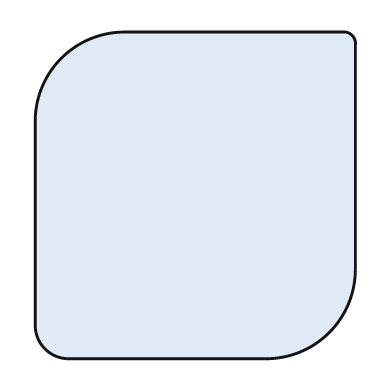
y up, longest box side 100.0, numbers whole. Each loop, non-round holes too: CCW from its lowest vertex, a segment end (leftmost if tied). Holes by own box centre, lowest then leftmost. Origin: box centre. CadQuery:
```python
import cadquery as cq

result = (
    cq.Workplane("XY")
    .moveTo(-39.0, -50.0)
    .lineTo(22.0, -50.0)
    .threePointArc((41.0, -42.0), (49.0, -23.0))
    .lineTo(49.0, 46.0)
    .threePointArc((48.0, 49.0), (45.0, 50.0))
    .lineTo(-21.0, 50.0)
    .threePointArc((-41.0, 42.0), (-49.0, 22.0))
    .lineTo(-49.0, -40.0)
    .threePointArc((-46.0, -47.0), (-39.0, -50.0))
    .close()
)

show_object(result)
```